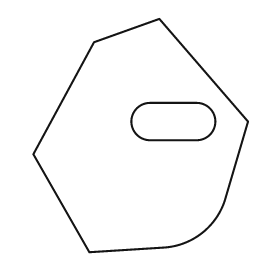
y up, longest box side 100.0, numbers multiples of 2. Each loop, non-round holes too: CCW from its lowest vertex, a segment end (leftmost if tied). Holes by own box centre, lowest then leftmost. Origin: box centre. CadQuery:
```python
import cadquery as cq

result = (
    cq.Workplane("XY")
    .moveTo(-22.0, -50.0)
    .lineTo(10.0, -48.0)
    .threePointArc((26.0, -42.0), (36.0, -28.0))
    .lineTo(46.0, 6.0)
    .lineTo(8.0, 50.0)
    .lineTo(-20.0, 40.0)
    .lineTo(-46.0, -8.0)
    .close()
    .moveTo(4.0, -2.0)
    .lineTo(24.0, -2.0)
    .threePointArc((32.0, 6.0), (24.0, 14.0))
    .lineTo(4.0, 14.0)
    .threePointArc((-4.0, 6.0), (4.0, -2.0))
    .close()
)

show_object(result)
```